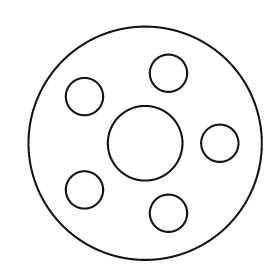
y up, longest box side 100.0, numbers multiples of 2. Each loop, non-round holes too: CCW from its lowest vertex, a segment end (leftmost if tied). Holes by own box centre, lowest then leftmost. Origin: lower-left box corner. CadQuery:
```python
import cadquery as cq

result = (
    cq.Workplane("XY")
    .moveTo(50.0, 50.0)
    .circle(50.0)
    .moveTo(60.0, 20.0)
    .circle(8.0)
    .moveTo(24.0, 30.0)
    .circle(8.0)
    .moveTo(50.0, 50.0)
    .circle(16.0)
    .moveTo(82.0, 50.0)
    .circle(8.0)
    .moveTo(24.0, 70.0)
    .circle(8.0)
    .moveTo(60.0, 80.0)
    .circle(8.0)
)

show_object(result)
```